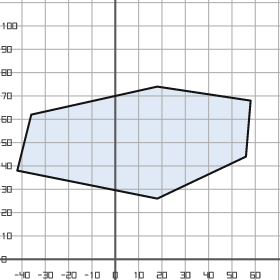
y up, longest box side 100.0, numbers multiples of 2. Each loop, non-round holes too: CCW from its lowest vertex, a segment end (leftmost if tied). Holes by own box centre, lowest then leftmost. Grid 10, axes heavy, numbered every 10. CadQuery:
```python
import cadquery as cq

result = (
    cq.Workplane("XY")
    .moveTo(18.0, 26.0)
    .lineTo(56.0, 44.0)
    .lineTo(58.0, 68.0)
    .lineTo(18.0, 74.0)
    .lineTo(-36.0, 62.0)
    .lineTo(-42.0, 38.0)
    .close()
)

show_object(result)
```